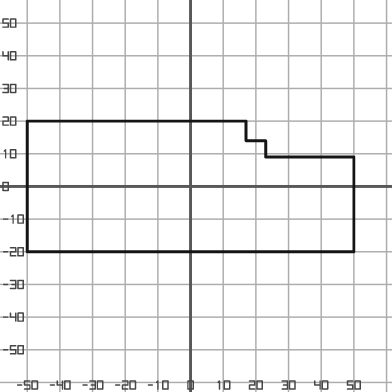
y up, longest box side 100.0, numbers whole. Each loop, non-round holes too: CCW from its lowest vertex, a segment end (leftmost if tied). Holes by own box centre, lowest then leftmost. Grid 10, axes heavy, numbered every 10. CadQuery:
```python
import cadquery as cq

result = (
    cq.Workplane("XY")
    .moveTo(-50.0, -20.0)
    .lineTo(50.0, -20.0)
    .lineTo(50.0, 9.0)
    .lineTo(23.0, 9.0)
    .lineTo(23.0, 14.0)
    .lineTo(17.0, 14.0)
    .lineTo(17.0, 20.0)
    .lineTo(-50.0, 20.0)
    .close()
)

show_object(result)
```